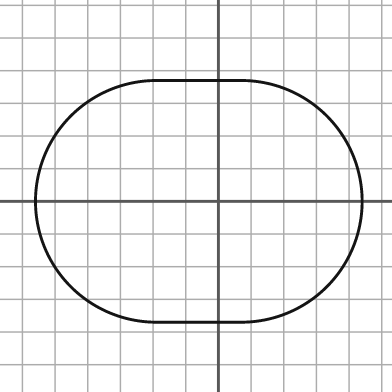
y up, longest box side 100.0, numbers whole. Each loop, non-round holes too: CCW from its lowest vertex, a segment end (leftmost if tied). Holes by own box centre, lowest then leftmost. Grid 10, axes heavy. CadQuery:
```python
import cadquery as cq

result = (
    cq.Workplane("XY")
    .moveTo(-19.0, -37.0)
    .lineTo(7.0, -37.0)
    .threePointArc((44.0, 0.0), (7.0, 37.0))
    .lineTo(-19.0, 37.0)
    .threePointArc((-56.0, 0.0), (-19.0, -37.0))
    .close()
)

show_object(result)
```